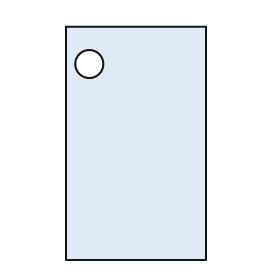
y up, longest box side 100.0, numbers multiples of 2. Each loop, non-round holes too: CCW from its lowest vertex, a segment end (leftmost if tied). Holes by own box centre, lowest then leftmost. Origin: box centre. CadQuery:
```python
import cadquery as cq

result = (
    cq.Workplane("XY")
    .moveTo(-30.0, -50.0)
    .lineTo(30.0, -50.0)
    .lineTo(30.0, 50.0)
    .lineTo(-30.0, 50.0)
    .close()
    .moveTo(-20.0, 34.0)
    .circle(6.0)
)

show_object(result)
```